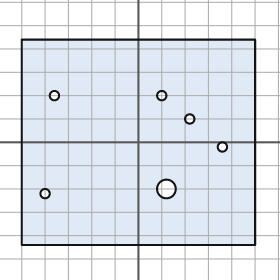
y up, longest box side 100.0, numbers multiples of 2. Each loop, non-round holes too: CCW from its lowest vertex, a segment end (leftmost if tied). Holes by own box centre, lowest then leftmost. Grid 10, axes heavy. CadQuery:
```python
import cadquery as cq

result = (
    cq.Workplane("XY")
    .moveTo(-50.0, -44.0)
    .lineTo(50.0, -44.0)
    .lineTo(50.0, 44.0)
    .lineTo(-50.0, 44.0)
    .close()
    .moveTo(-40.0, -22.0)
    .circle(2.0)
    .moveTo(12.0, -20.0)
    .circle(4.0)
    .moveTo(36.0, -2.0)
    .circle(2.0)
    .moveTo(22.0, 10.0)
    .circle(2.0)
    .moveTo(-36.0, 20.0)
    .circle(2.0)
    .moveTo(10.0, 20.0)
    .circle(2.0)
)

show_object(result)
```